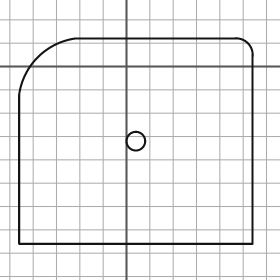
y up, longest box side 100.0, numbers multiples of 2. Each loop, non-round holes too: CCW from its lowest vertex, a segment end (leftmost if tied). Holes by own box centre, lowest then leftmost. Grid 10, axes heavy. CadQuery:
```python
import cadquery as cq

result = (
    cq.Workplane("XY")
    .moveTo(-46.0, -76.0)
    .lineTo(54.0, -76.0)
    .lineTo(54.0, 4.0)
    .threePointArc((52.0, 10.0), (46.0, 12.0))
    .lineTo(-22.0, 12.0)
    .threePointArc((-38.0, 4.0), (-46.0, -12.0))
    .close()
    .moveTo(4.0, -32.0)
    .circle(4.0)
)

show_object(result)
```